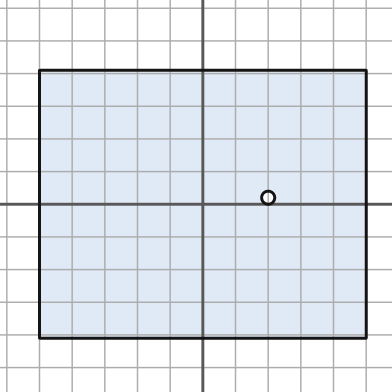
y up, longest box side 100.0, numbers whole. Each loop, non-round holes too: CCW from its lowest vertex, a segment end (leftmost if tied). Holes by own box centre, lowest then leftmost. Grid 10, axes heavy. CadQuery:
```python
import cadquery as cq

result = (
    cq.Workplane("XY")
    .moveTo(-50.0, -41.0)
    .lineTo(50.0, -41.0)
    .lineTo(50.0, 41.0)
    .lineTo(-50.0, 41.0)
    .close()
    .moveTo(20.0, 2.0)
    .circle(2.0)
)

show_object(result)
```